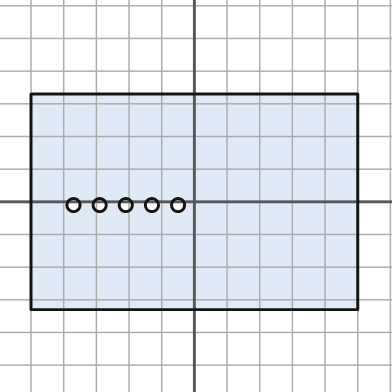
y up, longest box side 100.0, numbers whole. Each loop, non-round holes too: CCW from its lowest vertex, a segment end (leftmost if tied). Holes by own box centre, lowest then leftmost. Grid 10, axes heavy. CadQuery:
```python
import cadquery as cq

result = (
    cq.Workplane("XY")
    .moveTo(-50.0, -33.0)
    .lineTo(50.0, -33.0)
    .lineTo(50.0, 33.0)
    .lineTo(-50.0, 33.0)
    .close()
    .moveTo(-37.0, -1.0)
    .circle(2.0)
    .moveTo(-29.0, -1.0)
    .circle(2.0)
    .moveTo(-21.0, -1.0)
    .circle(2.0)
    .moveTo(-13.0, -1.0)
    .circle(2.0)
    .moveTo(-5.0, -1.0)
    .circle(2.0)
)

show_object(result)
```